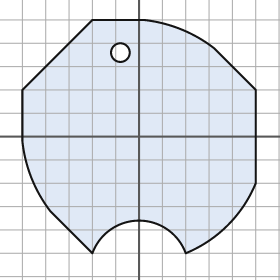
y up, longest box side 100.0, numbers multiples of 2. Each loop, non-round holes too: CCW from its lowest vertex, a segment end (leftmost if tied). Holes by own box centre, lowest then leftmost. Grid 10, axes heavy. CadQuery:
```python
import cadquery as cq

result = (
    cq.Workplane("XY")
    .moveTo(-20.0, -50.0)
    .threePointArc((0.0, -36.0), (20.0, -50.0))
    .threePointArc((38.0, -38.0), (50.0, -20.0))
    .lineTo(50.0, 20.0)
    .lineTo(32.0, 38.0)
    .threePointArc((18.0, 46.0), (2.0, 50.0))
    .lineTo(-20.0, 50.0)
    .lineTo(-50.0, 20.0)
    .lineTo(-50.0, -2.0)
    .threePointArc((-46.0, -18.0), (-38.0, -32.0))
    .close()
    .moveTo(-8.0, 36.0)
    .circle(4.0)
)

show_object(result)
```